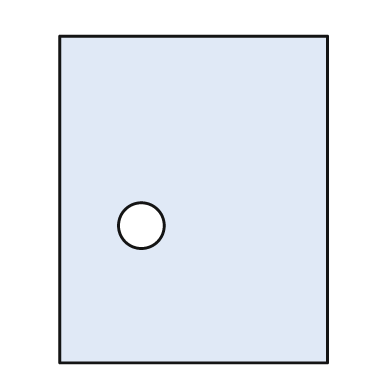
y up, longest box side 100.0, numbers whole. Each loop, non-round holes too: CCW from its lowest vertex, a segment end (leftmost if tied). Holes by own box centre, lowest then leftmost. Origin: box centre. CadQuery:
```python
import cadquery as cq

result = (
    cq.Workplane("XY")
    .moveTo(-41.0, -50.0)
    .lineTo(41.0, -50.0)
    .lineTo(41.0, 50.0)
    .lineTo(-41.0, 50.0)
    .close()
    .moveTo(-16.0, -8.0)
    .circle(7.0)
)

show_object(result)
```